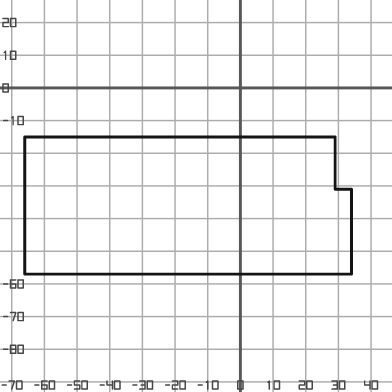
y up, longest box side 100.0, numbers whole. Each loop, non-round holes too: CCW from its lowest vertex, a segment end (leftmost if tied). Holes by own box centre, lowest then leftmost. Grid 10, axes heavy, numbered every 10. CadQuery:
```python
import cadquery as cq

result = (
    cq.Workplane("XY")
    .moveTo(-66.0, -57.0)
    .lineTo(34.0, -57.0)
    .lineTo(34.0, -31.0)
    .lineTo(29.0, -31.0)
    .lineTo(29.0, -15.0)
    .lineTo(-66.0, -15.0)
    .close()
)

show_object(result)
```